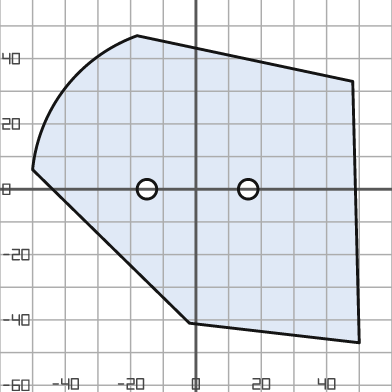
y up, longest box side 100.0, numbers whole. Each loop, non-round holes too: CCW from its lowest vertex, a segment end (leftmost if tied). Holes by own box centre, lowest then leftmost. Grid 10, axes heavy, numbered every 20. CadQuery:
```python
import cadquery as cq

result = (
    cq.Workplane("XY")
    .moveTo(50.0, -47.0)
    .lineTo(48.0, 33.0)
    .lineTo(-18.0, 47.0)
    .threePointArc((-40.0, 31.0), (-50.0, 6.0))
    .lineTo(-2.0, -41.0)
    .close()
    .moveTo(-15.0, 0.0)
    .circle(3.0)
    .moveTo(16.0, 0.0)
    .circle(3.0)
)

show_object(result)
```